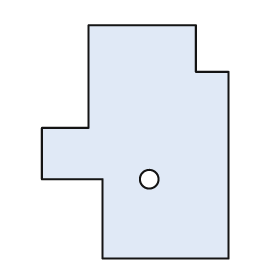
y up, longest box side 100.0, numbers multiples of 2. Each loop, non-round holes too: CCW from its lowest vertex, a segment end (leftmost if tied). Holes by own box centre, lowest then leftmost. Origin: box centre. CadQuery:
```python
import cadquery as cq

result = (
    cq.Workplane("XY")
    .moveTo(-14.0, -50.0)
    .lineTo(40.0, -50.0)
    .lineTo(40.0, 30.0)
    .lineTo(26.0, 30.0)
    .lineTo(26.0, 50.0)
    .lineTo(-20.0, 50.0)
    .lineTo(-20.0, 6.0)
    .lineTo(-40.0, 6.0)
    .lineTo(-40.0, -16.0)
    .lineTo(-14.0, -16.0)
    .close()
    .moveTo(6.0, -16.0)
    .circle(4.0)
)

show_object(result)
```